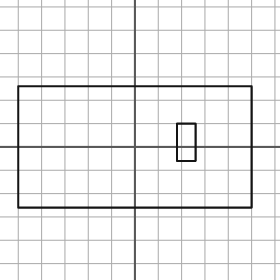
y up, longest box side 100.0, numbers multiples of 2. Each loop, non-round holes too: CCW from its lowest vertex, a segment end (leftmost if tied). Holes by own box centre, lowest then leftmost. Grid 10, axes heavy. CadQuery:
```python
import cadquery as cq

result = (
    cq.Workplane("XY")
    .moveTo(-50.0, -26.0)
    .lineTo(50.0, -26.0)
    .lineTo(50.0, 26.0)
    .lineTo(-50.0, 26.0)
    .close()
    .moveTo(18.0, -6.0)
    .lineTo(26.0, -6.0)
    .lineTo(26.0, 10.0)
    .lineTo(18.0, 10.0)
    .close()
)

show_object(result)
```